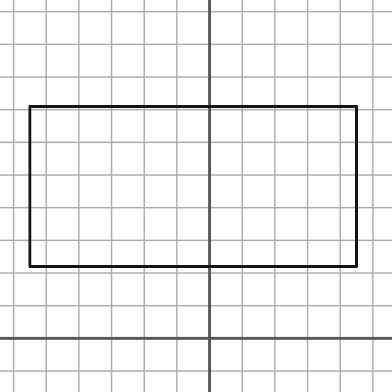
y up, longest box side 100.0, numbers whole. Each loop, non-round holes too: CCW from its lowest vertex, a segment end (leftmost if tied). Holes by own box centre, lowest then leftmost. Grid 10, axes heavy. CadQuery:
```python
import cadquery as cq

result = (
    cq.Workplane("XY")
    .moveTo(-55.0, 22.0)
    .lineTo(45.0, 22.0)
    .lineTo(45.0, 71.0)
    .lineTo(-55.0, 71.0)
    .close()
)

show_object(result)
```